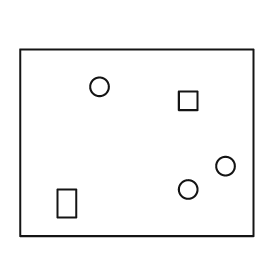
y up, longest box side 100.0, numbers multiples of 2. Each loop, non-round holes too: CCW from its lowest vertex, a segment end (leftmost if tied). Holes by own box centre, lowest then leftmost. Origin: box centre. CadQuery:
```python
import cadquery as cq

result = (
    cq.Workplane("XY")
    .moveTo(-50.0, -40.0)
    .lineTo(50.0, -40.0)
    .lineTo(50.0, 40.0)
    .lineTo(-50.0, 40.0)
    .close()
    .moveTo(-34.0, -32.0)
    .lineTo(-26.0, -32.0)
    .lineTo(-26.0, -20.0)
    .lineTo(-34.0, -20.0)
    .close()
    .moveTo(22.0, -20.0)
    .circle(4.0)
    .moveTo(38.0, -10.0)
    .circle(4.0)
    .moveTo(18.0, 14.0)
    .lineTo(26.0, 14.0)
    .lineTo(26.0, 22.0)
    .lineTo(18.0, 22.0)
    .close()
    .moveTo(-16.0, 24.0)
    .circle(4.0)
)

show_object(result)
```